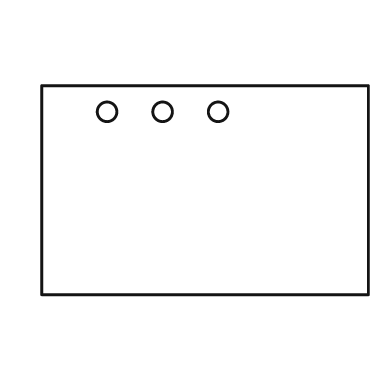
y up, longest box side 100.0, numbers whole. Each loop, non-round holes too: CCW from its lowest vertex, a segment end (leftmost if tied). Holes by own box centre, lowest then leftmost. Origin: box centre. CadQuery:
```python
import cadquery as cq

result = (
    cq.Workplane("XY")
    .moveTo(-50.0, -32.0)
    .lineTo(50.0, -32.0)
    .lineTo(50.0, 32.0)
    .lineTo(-50.0, 32.0)
    .close()
    .moveTo(-30.0, 24.0)
    .circle(3.0)
    .moveTo(-13.0, 24.0)
    .circle(3.0)
    .moveTo(4.0, 24.0)
    .circle(3.0)
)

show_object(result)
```